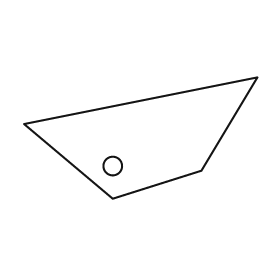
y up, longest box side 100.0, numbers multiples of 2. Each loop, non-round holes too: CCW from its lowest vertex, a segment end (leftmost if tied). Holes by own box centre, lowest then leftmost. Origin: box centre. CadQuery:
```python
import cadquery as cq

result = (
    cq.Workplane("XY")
    .moveTo(-12.0, -26.0)
    .lineTo(26.0, -14.0)
    .lineTo(50.0, 26.0)
    .lineTo(-50.0, 6.0)
    .close()
    .moveTo(-12.0, -12.0)
    .circle(4.0)
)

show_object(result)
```